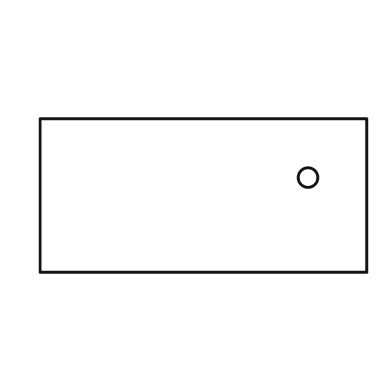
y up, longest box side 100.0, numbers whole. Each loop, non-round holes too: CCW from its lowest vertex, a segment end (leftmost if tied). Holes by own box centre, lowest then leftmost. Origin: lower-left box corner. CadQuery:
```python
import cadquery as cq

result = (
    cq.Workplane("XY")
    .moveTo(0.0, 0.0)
    .lineTo(100.0, 0.0)
    .lineTo(100.0, 47.0)
    .lineTo(0.0, 47.0)
    .close()
    .moveTo(82.0, 29.0)
    .circle(3.0)
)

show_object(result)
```